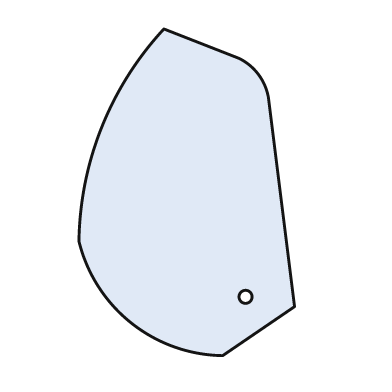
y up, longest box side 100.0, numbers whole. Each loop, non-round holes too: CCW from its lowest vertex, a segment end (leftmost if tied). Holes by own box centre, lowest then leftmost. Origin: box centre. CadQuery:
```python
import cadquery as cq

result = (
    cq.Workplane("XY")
    .moveTo(11.0, -50.0)
    .lineTo(33.0, -35.0)
    .lineTo(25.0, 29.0)
    .threePointArc((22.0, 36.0), (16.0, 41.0))
    .lineTo(-7.0, 50.0)
    .threePointArc((-26.0, 20.0), (-33.0, -15.0))
    .threePointArc((-17.0, -40.0), (11.0, -50.0))
    .close()
    .moveTo(18.0, -32.0)
    .circle(2.0)
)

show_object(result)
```